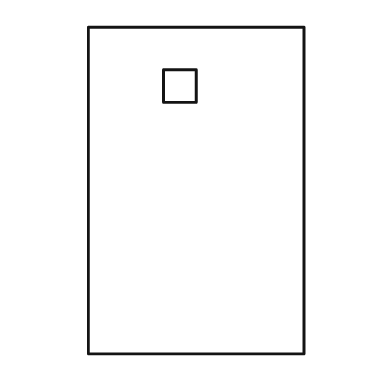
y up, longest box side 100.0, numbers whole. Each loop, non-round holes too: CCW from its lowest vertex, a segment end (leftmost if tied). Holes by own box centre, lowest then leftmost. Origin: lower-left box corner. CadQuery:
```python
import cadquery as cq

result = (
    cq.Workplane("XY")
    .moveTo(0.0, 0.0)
    .lineTo(66.0, 0.0)
    .lineTo(66.0, 100.0)
    .lineTo(0.0, 100.0)
    .close()
    .moveTo(23.0, 77.0)
    .lineTo(33.0, 77.0)
    .lineTo(33.0, 87.0)
    .lineTo(23.0, 87.0)
    .close()
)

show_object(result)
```